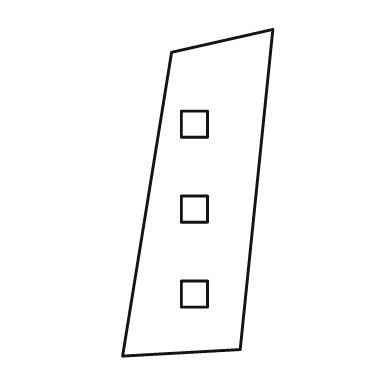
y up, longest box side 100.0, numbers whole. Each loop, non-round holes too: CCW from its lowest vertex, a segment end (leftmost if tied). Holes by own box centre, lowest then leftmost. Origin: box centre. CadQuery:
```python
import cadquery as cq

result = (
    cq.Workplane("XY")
    .moveTo(-23.0, -50.0)
    .lineTo(13.0, -48.0)
    .lineTo(23.0, 50.0)
    .lineTo(-8.0, 43.0)
    .close()
    .moveTo(-5.0, -35.0)
    .lineTo(3.0, -35.0)
    .lineTo(3.0, -27.0)
    .lineTo(-5.0, -27.0)
    .close()
    .moveTo(-5.0, -9.0)
    .lineTo(3.0, -9.0)
    .lineTo(3.0, -1.0)
    .lineTo(-5.0, -1.0)
    .close()
    .moveTo(-5.0, 17.0)
    .lineTo(3.0, 17.0)
    .lineTo(3.0, 25.0)
    .lineTo(-5.0, 25.0)
    .close()
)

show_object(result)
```